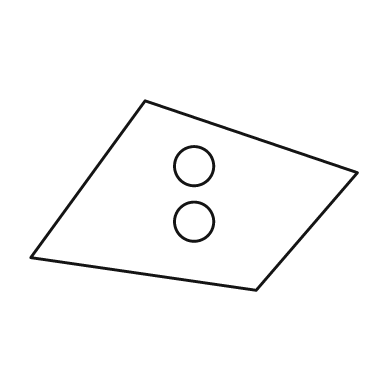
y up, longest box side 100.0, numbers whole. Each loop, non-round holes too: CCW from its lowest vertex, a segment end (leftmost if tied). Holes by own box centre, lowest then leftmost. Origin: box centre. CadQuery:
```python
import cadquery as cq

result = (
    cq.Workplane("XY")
    .moveTo(19.0, -29.0)
    .lineTo(50.0, 7.0)
    .lineTo(-15.0, 29.0)
    .lineTo(-50.0, -19.0)
    .close()
    .moveTo(0.0, -8.0)
    .circle(6.0)
    .moveTo(0.0, 9.0)
    .circle(6.0)
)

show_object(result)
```